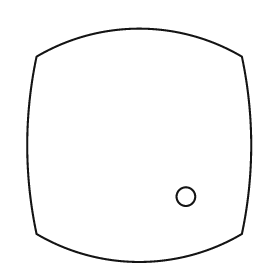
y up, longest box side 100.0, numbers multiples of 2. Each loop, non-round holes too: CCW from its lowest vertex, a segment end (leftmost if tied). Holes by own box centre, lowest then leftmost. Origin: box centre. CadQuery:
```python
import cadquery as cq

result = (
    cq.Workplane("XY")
    .moveTo(-44.0, -38.0)
    .threePointArc((0.0, -50.0), (44.0, -38.0))
    .threePointArc((48.0, 0.0), (44.0, 38.0))
    .threePointArc((0.0, 50.0), (-44.0, 38.0))
    .threePointArc((-48.0, 0.0), (-44.0, -38.0))
    .close()
    .moveTo(20.0, -22.0)
    .circle(4.0)
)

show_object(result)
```